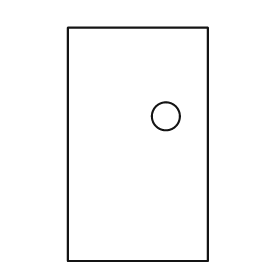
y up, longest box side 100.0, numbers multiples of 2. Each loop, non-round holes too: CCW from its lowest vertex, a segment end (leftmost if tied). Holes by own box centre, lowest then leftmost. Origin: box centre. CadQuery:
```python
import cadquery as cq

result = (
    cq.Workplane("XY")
    .moveTo(-30.0, -50.0)
    .lineTo(30.0, -50.0)
    .lineTo(30.0, 50.0)
    .lineTo(-30.0, 50.0)
    .close()
    .moveTo(12.0, 12.0)
    .circle(6.0)
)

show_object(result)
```